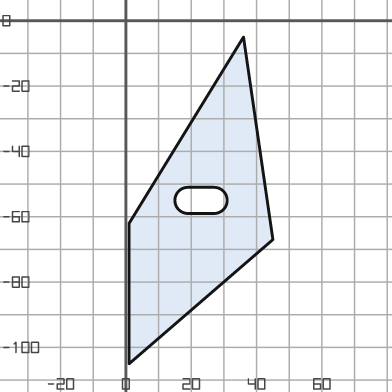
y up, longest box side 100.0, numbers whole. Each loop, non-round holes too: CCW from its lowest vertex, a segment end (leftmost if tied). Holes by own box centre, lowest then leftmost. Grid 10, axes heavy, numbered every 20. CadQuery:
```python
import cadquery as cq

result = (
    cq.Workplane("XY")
    .moveTo(1.0, -105.0)
    .lineTo(45.0, -67.0)
    .lineTo(36.0, -5.0)
    .lineTo(1.0, -62.0)
    .close()
    .moveTo(19.0, -59.0)
    .lineTo(27.0, -59.0)
    .threePointArc((31.0, -55.0), (27.0, -51.0))
    .lineTo(19.0, -51.0)
    .threePointArc((15.0, -55.0), (19.0, -59.0))
    .close()
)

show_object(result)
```